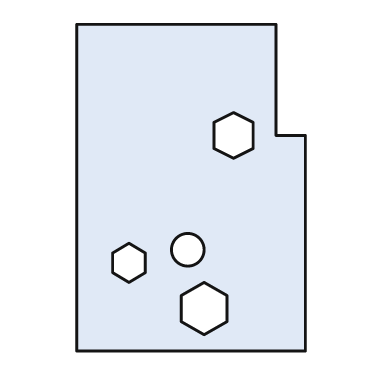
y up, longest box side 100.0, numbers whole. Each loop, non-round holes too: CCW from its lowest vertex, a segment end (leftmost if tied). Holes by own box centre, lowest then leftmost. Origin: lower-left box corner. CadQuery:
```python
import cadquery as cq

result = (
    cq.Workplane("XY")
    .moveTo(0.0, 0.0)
    .lineTo(70.0, 0.0)
    .lineTo(70.0, 66.0)
    .lineTo(61.0, 66.0)
    .lineTo(61.0, 100.0)
    .lineTo(0.0, 100.0)
    .close()
    .moveTo(39.0, 5.0)
    .lineTo(46.0, 9.0)
    .lineTo(46.0, 17.0)
    .lineTo(39.0, 21.0)
    .lineTo(32.0, 17.0)
    .lineTo(32.0, 9.0)
    .close()
    .moveTo(16.0, 21.0)
    .lineTo(21.0, 24.0)
    .lineTo(21.0, 30.0)
    .lineTo(16.0, 33.0)
    .lineTo(11.0, 30.0)
    .lineTo(11.0, 24.0)
    .close()
    .moveTo(34.0, 31.0)
    .circle(5.0)
    .moveTo(48.0, 59.0)
    .lineTo(54.0, 62.0)
    .lineTo(54.0, 70.0)
    .lineTo(48.0, 73.0)
    .lineTo(42.0, 70.0)
    .lineTo(42.0, 62.0)
    .close()
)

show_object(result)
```